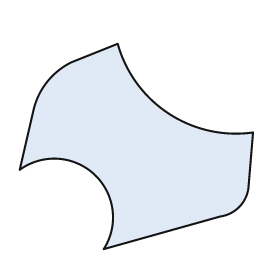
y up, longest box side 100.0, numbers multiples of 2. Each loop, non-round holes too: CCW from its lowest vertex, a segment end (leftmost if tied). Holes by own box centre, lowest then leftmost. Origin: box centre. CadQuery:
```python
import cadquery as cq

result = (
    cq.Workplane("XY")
    .moveTo(-14.0, -44.0)
    .lineTo(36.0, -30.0)
    .threePointArc((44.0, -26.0), (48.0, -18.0))
    .lineTo(50.0, 6.0)
    .threePointArc((14.0, 14.0), (-8.0, 44.0))
    .lineTo(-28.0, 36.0)
    .threePointArc((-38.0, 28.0), (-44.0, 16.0))
    .lineTo(-50.0, -10.0)
    .threePointArc((-18.0, -12.0), (-14.0, -44.0))
    .close()
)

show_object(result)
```